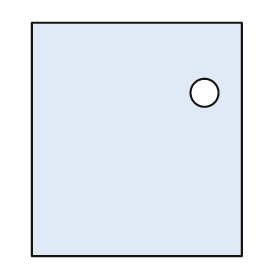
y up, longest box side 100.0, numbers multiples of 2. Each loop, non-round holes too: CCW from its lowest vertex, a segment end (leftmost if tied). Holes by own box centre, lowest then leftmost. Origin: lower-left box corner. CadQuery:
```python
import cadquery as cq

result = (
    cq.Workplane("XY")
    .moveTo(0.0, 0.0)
    .lineTo(90.0, 0.0)
    .lineTo(90.0, 100.0)
    .lineTo(0.0, 100.0)
    .close()
    .moveTo(74.0, 70.0)
    .circle(6.0)
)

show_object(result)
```